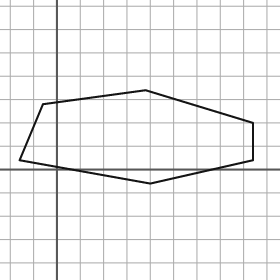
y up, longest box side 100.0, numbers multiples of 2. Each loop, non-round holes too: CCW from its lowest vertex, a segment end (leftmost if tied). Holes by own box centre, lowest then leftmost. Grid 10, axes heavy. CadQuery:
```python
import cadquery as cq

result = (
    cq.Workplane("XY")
    .moveTo(40.0, -6.0)
    .lineTo(84.0, 4.0)
    .lineTo(84.0, 20.0)
    .lineTo(38.0, 34.0)
    .lineTo(-6.0, 28.0)
    .lineTo(-16.0, 4.0)
    .close()
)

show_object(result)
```